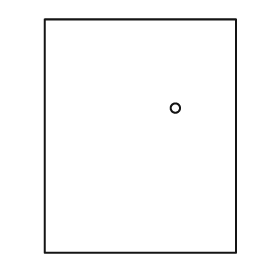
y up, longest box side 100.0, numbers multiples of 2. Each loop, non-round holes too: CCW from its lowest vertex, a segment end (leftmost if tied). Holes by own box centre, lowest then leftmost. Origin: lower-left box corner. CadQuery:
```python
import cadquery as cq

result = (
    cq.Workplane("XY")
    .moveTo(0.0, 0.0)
    .lineTo(82.0, 0.0)
    .lineTo(82.0, 100.0)
    .lineTo(0.0, 100.0)
    .close()
    .moveTo(56.0, 62.0)
    .circle(2.0)
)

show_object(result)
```